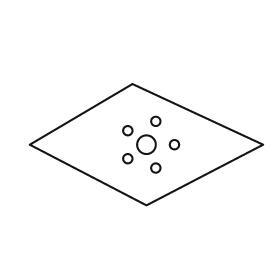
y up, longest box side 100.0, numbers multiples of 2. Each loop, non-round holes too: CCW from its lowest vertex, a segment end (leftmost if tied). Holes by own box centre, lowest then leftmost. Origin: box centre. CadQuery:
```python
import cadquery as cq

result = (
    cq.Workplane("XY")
    .moveTo(0.0, -26.0)
    .lineTo(50.0, 0.0)
    .lineTo(-6.0, 26.0)
    .lineTo(-50.0, 0.0)
    .close()
    .moveTo(4.0, -10.0)
    .circle(2.0)
    .moveTo(-8.0, -6.0)
    .circle(2.0)
    .moveTo(0.0, 0.0)
    .circle(4.0)
    .moveTo(12.0, 0.0)
    .circle(2.0)
    .moveTo(-8.0, 6.0)
    .circle(2.0)
    .moveTo(4.0, 10.0)
    .circle(2.0)
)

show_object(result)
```